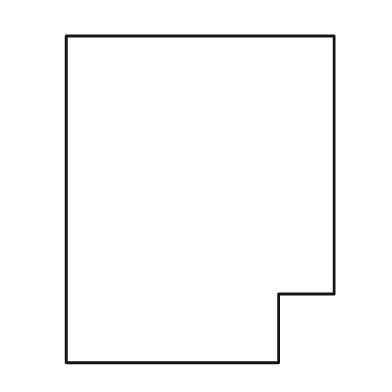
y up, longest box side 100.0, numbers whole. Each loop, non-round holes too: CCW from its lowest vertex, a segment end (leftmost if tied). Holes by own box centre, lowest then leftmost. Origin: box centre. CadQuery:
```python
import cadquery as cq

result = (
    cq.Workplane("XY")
    .moveTo(-41.0, -50.0)
    .lineTo(24.0, -50.0)
    .lineTo(24.0, -29.0)
    .lineTo(41.0, -29.0)
    .lineTo(41.0, 50.0)
    .lineTo(-41.0, 50.0)
    .close()
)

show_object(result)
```